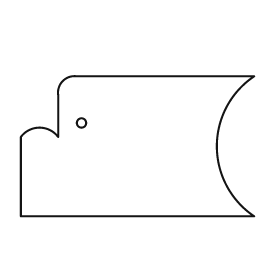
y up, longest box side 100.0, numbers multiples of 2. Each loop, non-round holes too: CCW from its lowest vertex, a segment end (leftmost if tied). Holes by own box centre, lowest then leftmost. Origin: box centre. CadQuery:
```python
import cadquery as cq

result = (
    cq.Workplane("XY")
    .moveTo(-50.0, -30.0)
    .lineTo(50.0, -30.0)
    .threePointArc((34.0, 0.0), (50.0, 30.0))
    .lineTo(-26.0, 30.0)
    .threePointArc((-32.0, 28.0), (-34.0, 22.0))
    .lineTo(-34.0, 4.0)
    .threePointArc((-42.0, 8.0), (-50.0, 4.0))
    .close()
    .moveTo(-24.0, 10.0)
    .circle(2.0)
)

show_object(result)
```